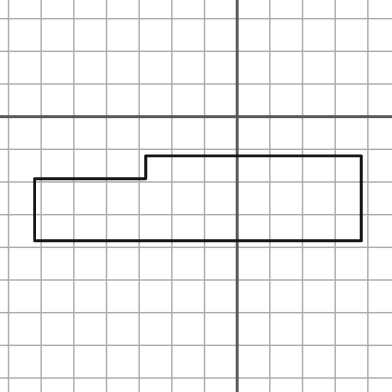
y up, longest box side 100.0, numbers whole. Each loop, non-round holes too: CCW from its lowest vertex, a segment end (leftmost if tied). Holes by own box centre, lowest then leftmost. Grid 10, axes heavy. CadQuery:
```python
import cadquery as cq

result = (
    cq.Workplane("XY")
    .moveTo(-62.0, -38.0)
    .lineTo(38.0, -38.0)
    .lineTo(38.0, -12.0)
    .lineTo(-28.0, -12.0)
    .lineTo(-28.0, -19.0)
    .lineTo(-62.0, -19.0)
    .close()
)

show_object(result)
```